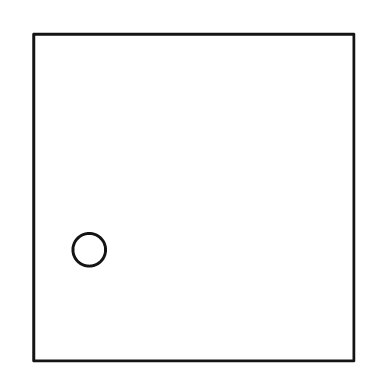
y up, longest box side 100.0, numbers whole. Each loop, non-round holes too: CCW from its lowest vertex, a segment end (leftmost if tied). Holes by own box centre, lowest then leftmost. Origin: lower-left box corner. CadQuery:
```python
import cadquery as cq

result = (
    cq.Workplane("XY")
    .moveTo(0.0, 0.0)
    .lineTo(98.0, 0.0)
    .lineTo(98.0, 100.0)
    .lineTo(0.0, 100.0)
    .close()
    .moveTo(17.0, 34.0)
    .circle(5.0)
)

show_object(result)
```